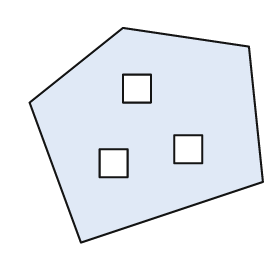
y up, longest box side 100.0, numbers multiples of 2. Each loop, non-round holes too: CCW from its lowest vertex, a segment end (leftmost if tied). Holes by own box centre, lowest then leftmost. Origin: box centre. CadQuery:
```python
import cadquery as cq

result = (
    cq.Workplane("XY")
    .moveTo(-28.0, -46.0)
    .lineTo(50.0, -20.0)
    .lineTo(44.0, 38.0)
    .lineTo(-10.0, 46.0)
    .lineTo(-50.0, 14.0)
    .close()
    .moveTo(-20.0, -18.0)
    .lineTo(-8.0, -18.0)
    .lineTo(-8.0, -6.0)
    .lineTo(-20.0, -6.0)
    .close()
    .moveTo(12.0, -12.0)
    .lineTo(24.0, -12.0)
    .lineTo(24.0, 0.0)
    .lineTo(12.0, 0.0)
    .close()
    .moveTo(-10.0, 14.0)
    .lineTo(2.0, 14.0)
    .lineTo(2.0, 26.0)
    .lineTo(-10.0, 26.0)
    .close()
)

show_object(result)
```